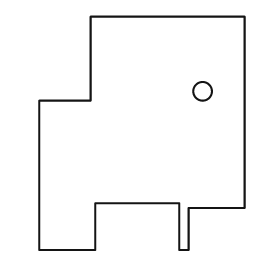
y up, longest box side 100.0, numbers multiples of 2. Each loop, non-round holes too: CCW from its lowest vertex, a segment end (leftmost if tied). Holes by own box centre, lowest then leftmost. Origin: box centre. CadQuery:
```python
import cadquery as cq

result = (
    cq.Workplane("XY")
    .moveTo(-44.0, -50.0)
    .lineTo(-20.0, -50.0)
    .lineTo(-20.0, -30.0)
    .lineTo(16.0, -30.0)
    .lineTo(16.0, -50.0)
    .lineTo(20.0, -50.0)
    .lineTo(20.0, -32.0)
    .lineTo(44.0, -32.0)
    .lineTo(44.0, 50.0)
    .lineTo(-22.0, 50.0)
    .lineTo(-22.0, 14.0)
    .lineTo(-44.0, 14.0)
    .close()
    .moveTo(26.0, 18.0)
    .circle(4.0)
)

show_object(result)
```